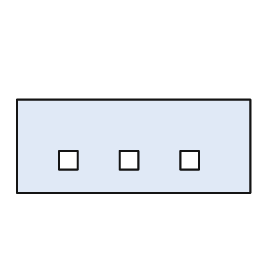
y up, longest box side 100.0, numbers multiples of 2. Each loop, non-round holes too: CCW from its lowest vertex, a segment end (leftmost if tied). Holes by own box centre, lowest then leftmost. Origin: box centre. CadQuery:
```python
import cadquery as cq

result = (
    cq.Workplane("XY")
    .moveTo(-50.0, -20.0)
    .lineTo(50.0, -20.0)
    .lineTo(50.0, 20.0)
    .lineTo(-50.0, 20.0)
    .close()
    .moveTo(-32.0, -10.0)
    .lineTo(-24.0, -10.0)
    .lineTo(-24.0, -2.0)
    .lineTo(-32.0, -2.0)
    .close()
    .moveTo(-6.0, -10.0)
    .lineTo(2.0, -10.0)
    .lineTo(2.0, -2.0)
    .lineTo(-6.0, -2.0)
    .close()
    .moveTo(20.0, -10.0)
    .lineTo(28.0, -10.0)
    .lineTo(28.0, -2.0)
    .lineTo(20.0, -2.0)
    .close()
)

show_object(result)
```